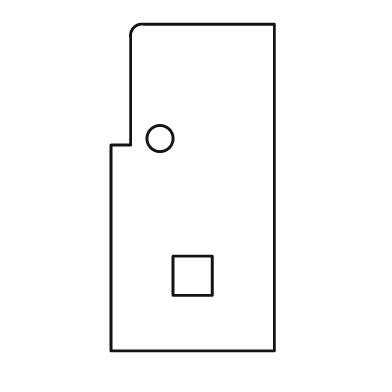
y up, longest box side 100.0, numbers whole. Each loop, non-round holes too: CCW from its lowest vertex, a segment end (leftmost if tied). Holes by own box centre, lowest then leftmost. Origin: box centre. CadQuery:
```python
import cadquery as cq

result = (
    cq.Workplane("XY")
    .moveTo(-25.0, -50.0)
    .lineTo(25.0, -50.0)
    .lineTo(25.0, 50.0)
    .lineTo(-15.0, 50.0)
    .threePointArc((-18.0, 49.0), (-19.0, 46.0))
    .lineTo(-19.0, 13.0)
    .lineTo(-25.0, 13.0)
    .close()
    .moveTo(-6.0, -33.0)
    .lineTo(6.0, -33.0)
    .lineTo(6.0, -21.0)
    .lineTo(-6.0, -21.0)
    .close()
    .moveTo(-10.0, 15.0)
    .circle(4.0)
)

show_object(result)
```